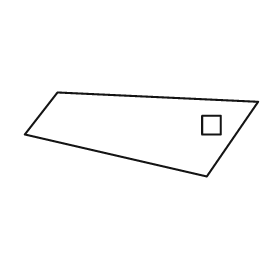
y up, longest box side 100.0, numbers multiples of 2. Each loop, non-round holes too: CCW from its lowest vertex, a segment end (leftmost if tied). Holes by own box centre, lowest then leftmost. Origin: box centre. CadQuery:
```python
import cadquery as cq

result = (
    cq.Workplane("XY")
    .moveTo(28.0, -18.0)
    .lineTo(50.0, 14.0)
    .lineTo(-36.0, 18.0)
    .lineTo(-50.0, 0.0)
    .close()
    .moveTo(26.0, 0.0)
    .lineTo(34.0, 0.0)
    .lineTo(34.0, 8.0)
    .lineTo(26.0, 8.0)
    .close()
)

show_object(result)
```